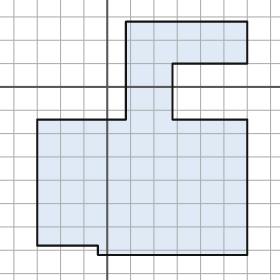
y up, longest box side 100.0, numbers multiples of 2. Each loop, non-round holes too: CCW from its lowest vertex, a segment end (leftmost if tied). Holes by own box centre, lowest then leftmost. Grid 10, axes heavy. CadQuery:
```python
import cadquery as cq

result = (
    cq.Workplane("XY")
    .moveTo(-4.0, -72.0)
    .lineTo(60.0, -72.0)
    .lineTo(60.0, -14.0)
    .lineTo(28.0, -14.0)
    .lineTo(28.0, 10.0)
    .lineTo(60.0, 10.0)
    .lineTo(60.0, 28.0)
    .lineTo(8.0, 28.0)
    .lineTo(8.0, -14.0)
    .lineTo(-30.0, -14.0)
    .lineTo(-30.0, -68.0)
    .lineTo(-4.0, -68.0)
    .close()
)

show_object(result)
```